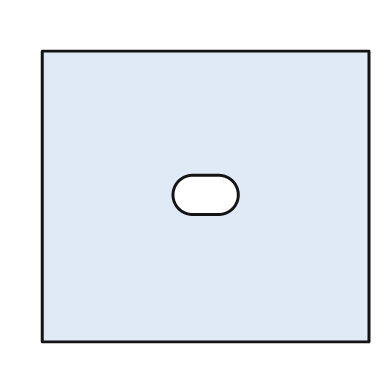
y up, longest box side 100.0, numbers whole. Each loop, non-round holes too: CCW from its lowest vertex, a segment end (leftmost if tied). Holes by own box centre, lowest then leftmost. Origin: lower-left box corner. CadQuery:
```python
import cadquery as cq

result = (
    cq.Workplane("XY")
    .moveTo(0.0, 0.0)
    .lineTo(100.0, 0.0)
    .lineTo(100.0, 89.0)
    .lineTo(0.0, 89.0)
    .close()
    .moveTo(46.0, 39.0)
    .lineTo(54.0, 39.0)
    .threePointArc((60.0, 45.0), (54.0, 51.0))
    .lineTo(46.0, 51.0)
    .threePointArc((40.0, 45.0), (46.0, 39.0))
    .close()
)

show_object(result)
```